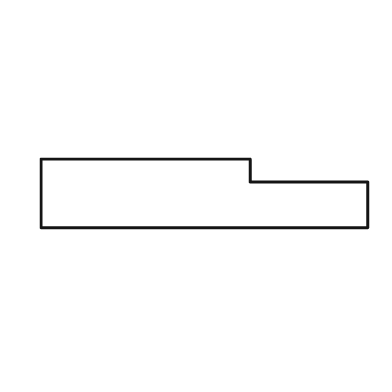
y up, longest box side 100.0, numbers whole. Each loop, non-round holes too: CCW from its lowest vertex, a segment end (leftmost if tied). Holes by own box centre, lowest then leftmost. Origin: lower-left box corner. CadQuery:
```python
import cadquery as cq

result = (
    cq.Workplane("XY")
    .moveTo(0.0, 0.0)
    .lineTo(100.0, 0.0)
    .lineTo(100.0, 14.0)
    .lineTo(64.0, 14.0)
    .lineTo(64.0, 21.0)
    .lineTo(0.0, 21.0)
    .close()
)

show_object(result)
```